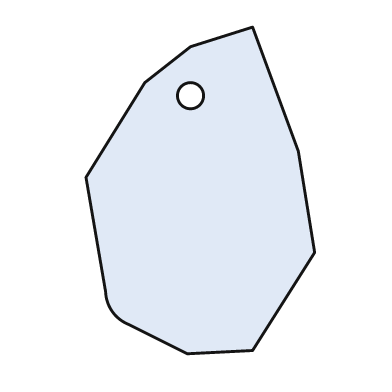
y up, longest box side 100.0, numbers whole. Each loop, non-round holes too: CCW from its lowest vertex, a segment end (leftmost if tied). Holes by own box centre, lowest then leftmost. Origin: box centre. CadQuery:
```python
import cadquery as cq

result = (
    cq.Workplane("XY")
    .moveTo(-4.0, -50.0)
    .lineTo(16.0, -49.0)
    .lineTo(35.0, -19.0)
    .lineTo(30.0, 12.0)
    .lineTo(16.0, 50.0)
    .lineTo(-3.0, 44.0)
    .lineTo(-17.0, 33.0)
    .lineTo(-35.0, 4.0)
    .lineTo(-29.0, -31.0)
    .threePointArc((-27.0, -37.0), (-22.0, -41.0))
    .close()
    .moveTo(-3.0, 29.0)
    .circle(4.0)
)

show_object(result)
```